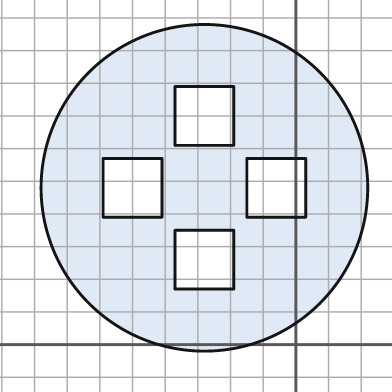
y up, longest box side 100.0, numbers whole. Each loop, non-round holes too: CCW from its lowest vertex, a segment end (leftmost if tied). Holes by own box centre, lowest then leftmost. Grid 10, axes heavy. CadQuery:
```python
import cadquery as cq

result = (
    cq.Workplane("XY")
    .moveTo(-28.0, 48.0)
    .circle(50.0)
    .moveTo(-37.0, 17.0)
    .lineTo(-19.0, 17.0)
    .lineTo(-19.0, 35.0)
    .lineTo(-37.0, 35.0)
    .close()
    .moveTo(-59.0, 39.0)
    .lineTo(-41.0, 39.0)
    .lineTo(-41.0, 57.0)
    .lineTo(-59.0, 57.0)
    .close()
    .moveTo(-15.0, 39.0)
    .lineTo(3.0, 39.0)
    .lineTo(3.0, 57.0)
    .lineTo(-15.0, 57.0)
    .close()
    .moveTo(-37.0, 61.0)
    .lineTo(-19.0, 61.0)
    .lineTo(-19.0, 79.0)
    .lineTo(-37.0, 79.0)
    .close()
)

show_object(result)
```